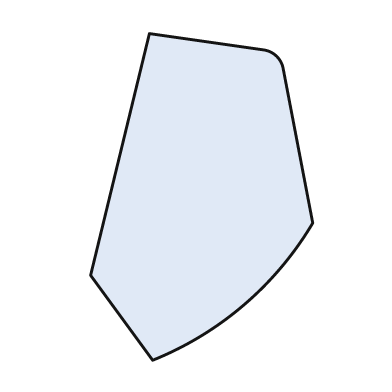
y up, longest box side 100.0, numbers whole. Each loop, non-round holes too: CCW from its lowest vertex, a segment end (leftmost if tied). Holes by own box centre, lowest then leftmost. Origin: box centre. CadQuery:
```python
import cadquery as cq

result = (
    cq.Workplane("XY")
    .moveTo(-15.0, -50.0)
    .threePointArc((13.0, -33.0), (34.0, -8.0))
    .lineTo(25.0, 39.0)
    .threePointArc((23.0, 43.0), (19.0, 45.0))
    .lineTo(-16.0, 50.0)
    .lineTo(-34.0, -24.0)
    .close()
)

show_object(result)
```